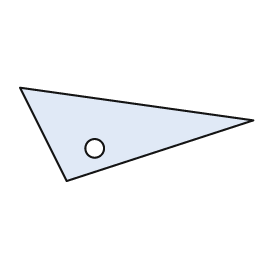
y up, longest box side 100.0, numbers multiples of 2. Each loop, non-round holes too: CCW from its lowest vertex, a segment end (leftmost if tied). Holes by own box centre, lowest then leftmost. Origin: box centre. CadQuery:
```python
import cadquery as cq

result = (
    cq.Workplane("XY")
    .moveTo(-30.0, -20.0)
    .lineTo(50.0, 6.0)
    .lineTo(-50.0, 20.0)
    .close()
    .moveTo(-18.0, -6.0)
    .circle(4.0)
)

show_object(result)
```